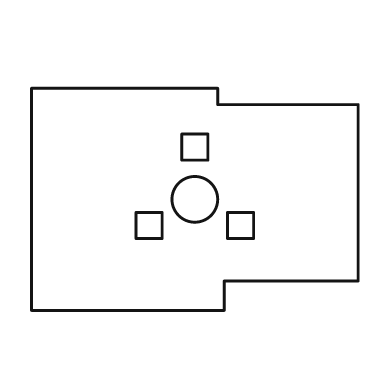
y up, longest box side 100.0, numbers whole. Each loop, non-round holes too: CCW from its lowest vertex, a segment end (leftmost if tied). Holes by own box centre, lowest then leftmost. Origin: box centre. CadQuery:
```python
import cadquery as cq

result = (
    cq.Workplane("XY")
    .moveTo(-50.0, -34.0)
    .lineTo(9.0, -34.0)
    .lineTo(9.0, -25.0)
    .lineTo(50.0, -25.0)
    .lineTo(50.0, 29.0)
    .lineTo(7.0, 29.0)
    .lineTo(7.0, 34.0)
    .lineTo(-50.0, 34.0)
    .close()
    .moveTo(-18.0, -12.0)
    .lineTo(-10.0, -12.0)
    .lineTo(-10.0, -4.0)
    .lineTo(-18.0, -4.0)
    .close()
    .moveTo(10.0, -12.0)
    .lineTo(18.0, -12.0)
    .lineTo(18.0, -4.0)
    .lineTo(10.0, -4.0)
    .close()
    .moveTo(0.0, 0.0)
    .circle(7.0)
    .moveTo(-4.0, 12.0)
    .lineTo(4.0, 12.0)
    .lineTo(4.0, 20.0)
    .lineTo(-4.0, 20.0)
    .close()
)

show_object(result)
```